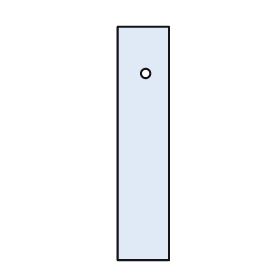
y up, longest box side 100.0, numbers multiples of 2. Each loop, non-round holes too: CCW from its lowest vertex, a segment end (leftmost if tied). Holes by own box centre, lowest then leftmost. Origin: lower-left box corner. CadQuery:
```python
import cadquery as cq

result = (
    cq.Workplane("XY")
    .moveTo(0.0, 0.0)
    .lineTo(22.0, 0.0)
    .lineTo(22.0, 100.0)
    .lineTo(0.0, 100.0)
    .close()
    .moveTo(12.0, 80.0)
    .circle(2.0)
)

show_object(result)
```